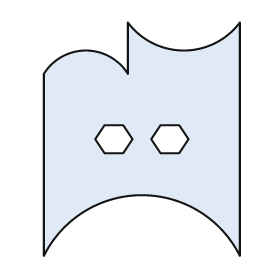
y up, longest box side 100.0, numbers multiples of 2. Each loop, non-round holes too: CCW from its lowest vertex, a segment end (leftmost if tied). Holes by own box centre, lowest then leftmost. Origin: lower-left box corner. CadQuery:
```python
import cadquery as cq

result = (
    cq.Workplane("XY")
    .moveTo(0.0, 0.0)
    .threePointArc((42.0, 26.0), (84.0, 0.0))
    .lineTo(84.0, 100.0)
    .threePointArc((60.0, 88.0), (36.0, 100.0))
    .lineTo(36.0, 78.0)
    .threePointArc((18.0, 88.0), (0.0, 78.0))
    .close()
    .moveTo(26.0, 44.0)
    .lineTo(34.0, 44.0)
    .lineTo(38.0, 50.0)
    .lineTo(34.0, 56.0)
    .lineTo(26.0, 56.0)
    .lineTo(22.0, 50.0)
    .close()
    .moveTo(50.0, 44.0)
    .lineTo(58.0, 44.0)
    .lineTo(62.0, 50.0)
    .lineTo(58.0, 56.0)
    .lineTo(50.0, 56.0)
    .lineTo(46.0, 50.0)
    .close()
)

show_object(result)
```